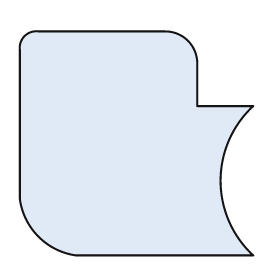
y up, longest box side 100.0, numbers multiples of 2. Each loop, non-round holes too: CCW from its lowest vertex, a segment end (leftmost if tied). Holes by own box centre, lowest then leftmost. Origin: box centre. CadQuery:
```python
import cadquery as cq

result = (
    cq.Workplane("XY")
    .moveTo(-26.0, -48.0)
    .lineTo(50.0, -48.0)
    .threePointArc((36.0, -16.0), (50.0, 16.0))
    .lineTo(26.0, 16.0)
    .lineTo(26.0, 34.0)
    .threePointArc((22.0, 44.0), (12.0, 48.0))
    .lineTo(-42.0, 48.0)
    .threePointArc((-48.0, 46.0), (-50.0, 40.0))
    .lineTo(-50.0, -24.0)
    .threePointArc((-42.0, -40.0), (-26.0, -48.0))
    .close()
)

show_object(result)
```